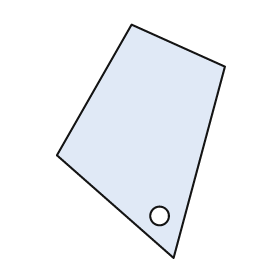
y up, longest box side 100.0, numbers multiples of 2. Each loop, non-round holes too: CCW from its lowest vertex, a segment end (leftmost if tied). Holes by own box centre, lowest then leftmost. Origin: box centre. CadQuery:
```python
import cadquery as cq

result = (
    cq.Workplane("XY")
    .moveTo(14.0, -50.0)
    .lineTo(36.0, 32.0)
    .lineTo(-4.0, 50.0)
    .lineTo(-36.0, -6.0)
    .close()
    .moveTo(8.0, -32.0)
    .circle(4.0)
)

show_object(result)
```